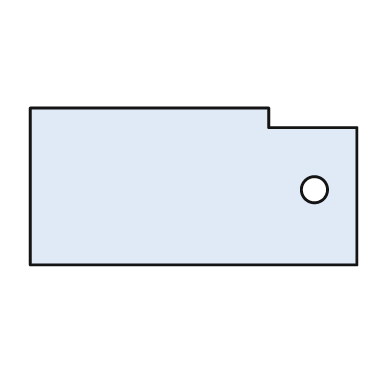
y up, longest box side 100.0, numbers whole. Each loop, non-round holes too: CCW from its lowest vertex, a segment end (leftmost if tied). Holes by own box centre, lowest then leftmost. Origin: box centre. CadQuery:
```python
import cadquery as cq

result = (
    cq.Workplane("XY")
    .moveTo(-50.0, -24.0)
    .lineTo(50.0, -24.0)
    .lineTo(50.0, 18.0)
    .lineTo(23.0, 18.0)
    .lineTo(23.0, 24.0)
    .lineTo(-50.0, 24.0)
    .close()
    .moveTo(37.0, -1.0)
    .circle(4.0)
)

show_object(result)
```